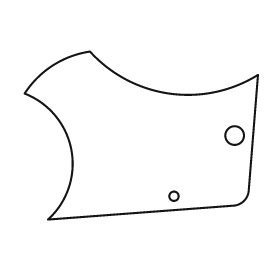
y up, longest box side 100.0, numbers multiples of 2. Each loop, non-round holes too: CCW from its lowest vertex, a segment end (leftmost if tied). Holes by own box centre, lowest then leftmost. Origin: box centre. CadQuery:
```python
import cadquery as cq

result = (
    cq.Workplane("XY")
    .moveTo(-40.0, -36.0)
    .lineTo(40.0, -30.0)
    .threePointArc((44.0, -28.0), (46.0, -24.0))
    .lineTo(50.0, 26.0)
    .threePointArc((12.0, 18.0), (-22.0, 36.0))
    .threePointArc((-38.0, 30.0), (-50.0, 18.0))
    .threePointArc((-30.0, -6.0), (-40.0, -36.0))
    .close()
    .moveTo(14.0, -26.0)
    .circle(2.0)
    .moveTo(40.0, 0.0)
    .circle(4.0)
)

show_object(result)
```